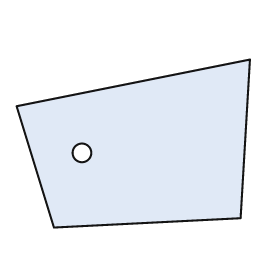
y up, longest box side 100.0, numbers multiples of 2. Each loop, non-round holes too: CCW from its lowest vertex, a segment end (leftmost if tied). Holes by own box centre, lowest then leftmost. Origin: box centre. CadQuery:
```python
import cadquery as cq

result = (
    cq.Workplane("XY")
    .moveTo(-34.0, -36.0)
    .lineTo(46.0, -32.0)
    .lineTo(50.0, 36.0)
    .lineTo(-50.0, 16.0)
    .close()
    .moveTo(-22.0, -4.0)
    .circle(4.0)
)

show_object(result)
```